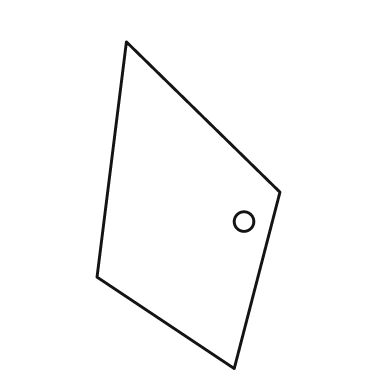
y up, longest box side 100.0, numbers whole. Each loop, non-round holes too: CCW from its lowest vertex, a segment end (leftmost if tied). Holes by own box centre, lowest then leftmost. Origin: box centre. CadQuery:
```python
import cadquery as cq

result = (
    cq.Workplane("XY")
    .moveTo(14.0, -50.0)
    .lineTo(28.0, 4.0)
    .lineTo(-19.0, 50.0)
    .lineTo(-28.0, -22.0)
    .close()
    .moveTo(17.0, -5.0)
    .circle(3.0)
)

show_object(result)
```